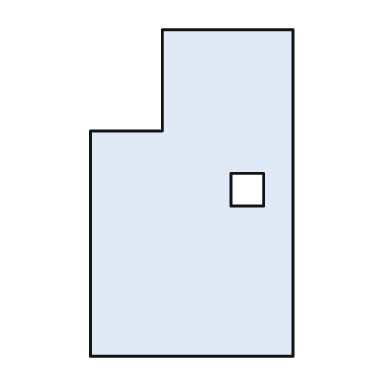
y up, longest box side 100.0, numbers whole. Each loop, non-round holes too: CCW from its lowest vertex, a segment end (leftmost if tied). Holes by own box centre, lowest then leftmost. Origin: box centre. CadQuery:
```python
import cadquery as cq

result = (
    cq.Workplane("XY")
    .moveTo(-31.0, -50.0)
    .lineTo(31.0, -50.0)
    .lineTo(31.0, 50.0)
    .lineTo(-9.0, 50.0)
    .lineTo(-9.0, 19.0)
    .lineTo(-31.0, 19.0)
    .close()
    .moveTo(12.0, -4.0)
    .lineTo(22.0, -4.0)
    .lineTo(22.0, 6.0)
    .lineTo(12.0, 6.0)
    .close()
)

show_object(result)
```